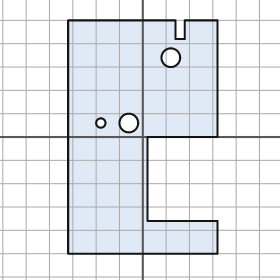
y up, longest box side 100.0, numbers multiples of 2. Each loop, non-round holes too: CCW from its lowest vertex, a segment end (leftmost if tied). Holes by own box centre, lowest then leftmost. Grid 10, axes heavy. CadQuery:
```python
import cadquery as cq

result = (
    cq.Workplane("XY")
    .moveTo(-32.0, -50.0)
    .lineTo(32.0, -50.0)
    .lineTo(32.0, -36.0)
    .lineTo(2.0, -36.0)
    .lineTo(2.0, 0.0)
    .lineTo(32.0, 0.0)
    .lineTo(32.0, 50.0)
    .lineTo(18.0, 50.0)
    .lineTo(18.0, 42.0)
    .lineTo(14.0, 42.0)
    .lineTo(14.0, 50.0)
    .lineTo(-32.0, 50.0)
    .close()
    .moveTo(-18.0, 6.0)
    .circle(2.0)
    .moveTo(-6.0, 6.0)
    .circle(4.0)
    .moveTo(12.0, 34.0)
    .circle(4.0)
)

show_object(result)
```